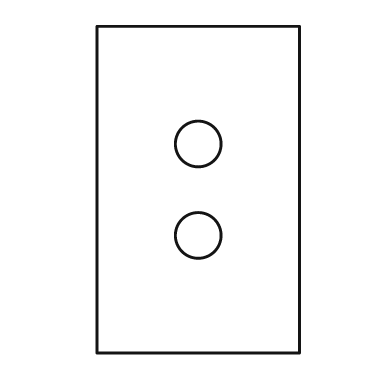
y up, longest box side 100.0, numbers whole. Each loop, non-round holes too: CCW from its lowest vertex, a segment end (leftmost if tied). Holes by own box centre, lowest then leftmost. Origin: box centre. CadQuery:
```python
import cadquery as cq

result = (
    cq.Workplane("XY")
    .moveTo(-31.0, -50.0)
    .lineTo(31.0, -50.0)
    .lineTo(31.0, 50.0)
    .lineTo(-31.0, 50.0)
    .close()
    .moveTo(0.0, -14.0)
    .circle(7.0)
    .moveTo(0.0, 14.0)
    .circle(7.0)
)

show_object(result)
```